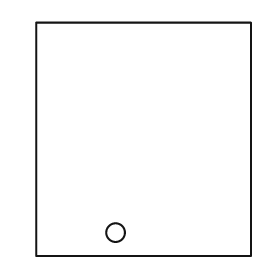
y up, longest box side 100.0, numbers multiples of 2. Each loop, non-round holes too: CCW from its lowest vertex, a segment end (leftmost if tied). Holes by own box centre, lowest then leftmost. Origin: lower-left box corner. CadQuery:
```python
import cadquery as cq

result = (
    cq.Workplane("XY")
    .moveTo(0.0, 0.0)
    .lineTo(92.0, 0.0)
    .lineTo(92.0, 100.0)
    .lineTo(0.0, 100.0)
    .close()
    .moveTo(34.0, 10.0)
    .circle(4.0)
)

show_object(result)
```